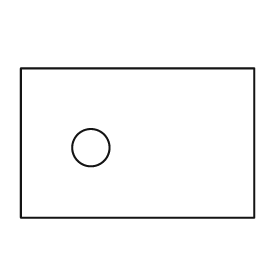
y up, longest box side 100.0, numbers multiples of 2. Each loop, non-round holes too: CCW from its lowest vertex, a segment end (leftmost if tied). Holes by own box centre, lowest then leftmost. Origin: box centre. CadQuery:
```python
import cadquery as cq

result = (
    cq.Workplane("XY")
    .moveTo(-50.0, -32.0)
    .lineTo(50.0, -32.0)
    .lineTo(50.0, 32.0)
    .lineTo(-50.0, 32.0)
    .close()
    .moveTo(-20.0, -2.0)
    .circle(8.0)
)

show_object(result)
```